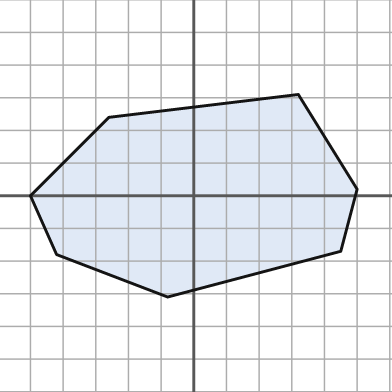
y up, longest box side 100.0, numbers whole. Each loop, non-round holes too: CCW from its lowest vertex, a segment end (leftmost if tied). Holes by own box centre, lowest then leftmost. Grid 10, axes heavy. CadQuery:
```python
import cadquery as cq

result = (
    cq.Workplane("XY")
    .moveTo(-8.0, -31.0)
    .lineTo(45.0, -17.0)
    .lineTo(50.0, 2.0)
    .lineTo(32.0, 31.0)
    .lineTo(-26.0, 24.0)
    .lineTo(-50.0, 0.0)
    .lineTo(-42.0, -18.0)
    .close()
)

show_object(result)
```